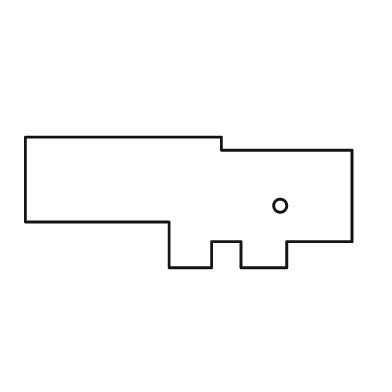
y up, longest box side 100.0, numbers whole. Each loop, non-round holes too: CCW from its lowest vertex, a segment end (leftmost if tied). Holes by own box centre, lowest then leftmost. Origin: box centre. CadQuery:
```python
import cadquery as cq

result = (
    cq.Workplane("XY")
    .moveTo(-6.0, -20.0)
    .lineTo(7.0, -20.0)
    .lineTo(7.0, -12.0)
    .lineTo(16.0, -12.0)
    .lineTo(16.0, -20.0)
    .lineTo(30.0, -20.0)
    .lineTo(30.0, -12.0)
    .lineTo(50.0, -12.0)
    .lineTo(50.0, 16.0)
    .lineTo(10.0, 16.0)
    .lineTo(10.0, 20.0)
    .lineTo(-50.0, 20.0)
    .lineTo(-50.0, -6.0)
    .lineTo(-6.0, -6.0)
    .close()
    .moveTo(28.0, -1.0)
    .circle(2.0)
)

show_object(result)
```